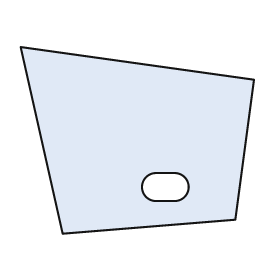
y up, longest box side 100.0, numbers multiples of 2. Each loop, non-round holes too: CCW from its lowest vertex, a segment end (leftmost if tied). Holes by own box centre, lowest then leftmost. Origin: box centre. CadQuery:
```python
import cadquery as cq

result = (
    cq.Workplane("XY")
    .moveTo(-32.0, -40.0)
    .lineTo(42.0, -34.0)
    .lineTo(50.0, 26.0)
    .lineTo(-50.0, 40.0)
    .close()
    .moveTo(8.0, -26.0)
    .lineTo(16.0, -26.0)
    .threePointArc((22.0, -20.0), (16.0, -14.0))
    .lineTo(8.0, -14.0)
    .threePointArc((2.0, -20.0), (8.0, -26.0))
    .close()
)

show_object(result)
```